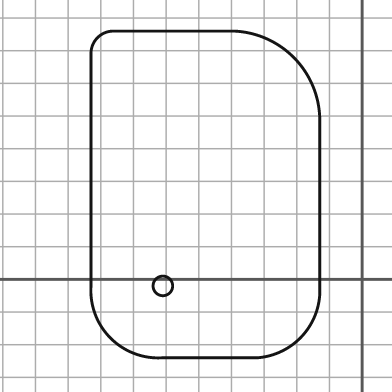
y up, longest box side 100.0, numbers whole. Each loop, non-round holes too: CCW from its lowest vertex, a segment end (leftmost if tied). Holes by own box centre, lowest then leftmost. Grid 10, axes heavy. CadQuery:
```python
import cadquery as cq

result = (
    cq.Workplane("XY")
    .moveTo(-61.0, -24.0)
    .lineTo(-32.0, -24.0)
    .threePointArc((-19.0, -18.0), (-13.0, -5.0))
    .lineTo(-13.0, 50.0)
    .threePointArc((-21.0, 68.0), (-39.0, 76.0))
    .lineTo(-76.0, 76.0)
    .threePointArc((-81.0, 74.0), (-83.0, 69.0))
    .lineTo(-83.0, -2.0)
    .threePointArc((-77.0, -18.0), (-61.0, -24.0))
    .close()
    .moveTo(-61.0, -2.0)
    .circle(3.0)
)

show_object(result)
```